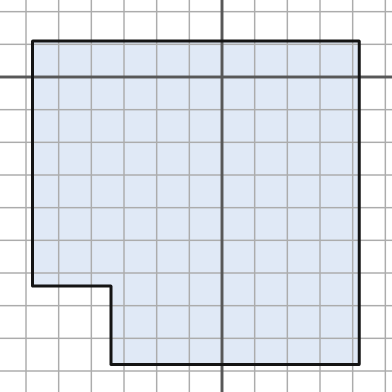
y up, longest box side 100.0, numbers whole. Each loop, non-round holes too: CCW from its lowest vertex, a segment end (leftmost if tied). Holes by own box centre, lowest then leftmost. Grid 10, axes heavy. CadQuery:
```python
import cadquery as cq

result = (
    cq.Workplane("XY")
    .moveTo(-34.0, -88.0)
    .lineTo(42.0, -88.0)
    .lineTo(42.0, 11.0)
    .lineTo(-58.0, 11.0)
    .lineTo(-58.0, -64.0)
    .lineTo(-34.0, -64.0)
    .close()
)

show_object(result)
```